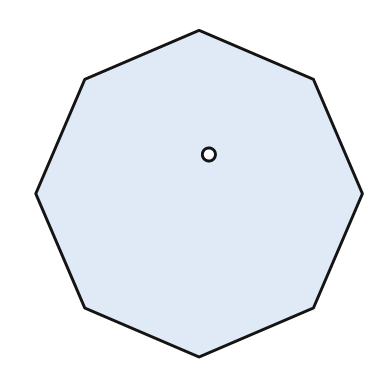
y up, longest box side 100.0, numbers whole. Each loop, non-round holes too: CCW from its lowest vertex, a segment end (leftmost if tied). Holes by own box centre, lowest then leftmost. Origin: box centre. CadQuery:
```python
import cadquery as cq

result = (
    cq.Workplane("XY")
    .moveTo(0.0, -50.0)
    .lineTo(35.0, -35.0)
    .lineTo(50.0, 0.0)
    .lineTo(35.0, 35.0)
    .lineTo(0.0, 50.0)
    .lineTo(-35.0, 35.0)
    .lineTo(-50.0, 0.0)
    .lineTo(-35.0, -35.0)
    .close()
    .moveTo(3.0, 12.0)
    .circle(2.0)
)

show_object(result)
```